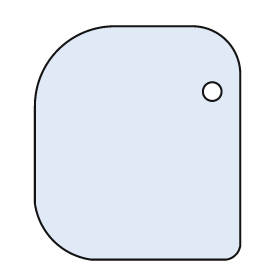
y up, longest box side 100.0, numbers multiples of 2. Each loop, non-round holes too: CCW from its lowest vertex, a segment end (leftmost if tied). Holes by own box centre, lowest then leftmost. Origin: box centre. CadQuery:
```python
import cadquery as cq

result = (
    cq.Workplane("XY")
    .moveTo(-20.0, -50.0)
    .lineTo(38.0, -50.0)
    .threePointArc((42.0, -48.0), (44.0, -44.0))
    .lineTo(44.0, 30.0)
    .threePointArc((38.0, 44.0), (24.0, 50.0))
    .lineTo(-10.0, 50.0)
    .threePointArc((-34.0, 40.0), (-44.0, 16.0))
    .lineTo(-44.0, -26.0)
    .threePointArc((-36.0, -42.0), (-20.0, -50.0))
    .close()
    .moveTo(32.0, 22.0)
    .circle(4.0)
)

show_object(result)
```